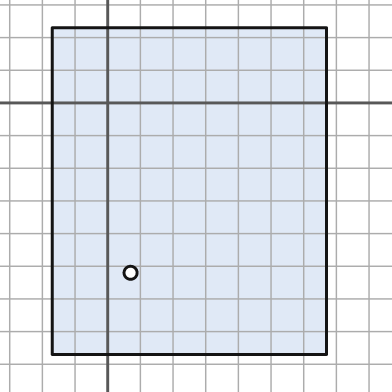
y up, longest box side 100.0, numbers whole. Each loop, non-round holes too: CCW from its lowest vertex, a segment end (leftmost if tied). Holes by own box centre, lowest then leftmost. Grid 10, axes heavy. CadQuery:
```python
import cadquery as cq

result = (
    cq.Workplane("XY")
    .moveTo(-17.0, -77.0)
    .lineTo(67.0, -77.0)
    .lineTo(67.0, 23.0)
    .lineTo(-17.0, 23.0)
    .close()
    .moveTo(7.0, -52.0)
    .circle(2.0)
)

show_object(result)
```